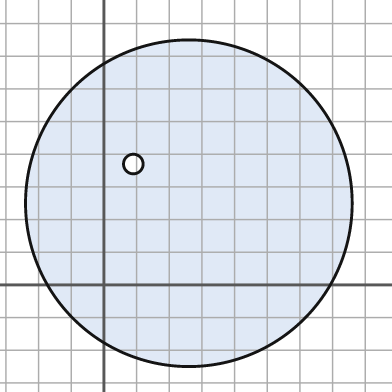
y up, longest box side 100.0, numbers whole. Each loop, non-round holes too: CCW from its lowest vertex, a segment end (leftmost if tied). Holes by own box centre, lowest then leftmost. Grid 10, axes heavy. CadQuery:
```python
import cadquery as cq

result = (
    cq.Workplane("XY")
    .moveTo(26.0, 25.0)
    .circle(50.0)
    .moveTo(9.0, 37.0)
    .circle(3.0)
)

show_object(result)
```